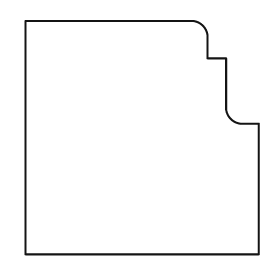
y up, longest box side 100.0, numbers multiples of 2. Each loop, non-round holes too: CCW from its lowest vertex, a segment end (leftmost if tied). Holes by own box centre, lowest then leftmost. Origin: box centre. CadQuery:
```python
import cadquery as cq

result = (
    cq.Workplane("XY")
    .moveTo(-50.0, -50.0)
    .lineTo(50.0, -50.0)
    .lineTo(50.0, 6.0)
    .lineTo(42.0, 6.0)
    .threePointArc((38.0, 8.0), (36.0, 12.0))
    .lineTo(36.0, 34.0)
    .lineTo(28.0, 34.0)
    .lineTo(28.0, 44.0)
    .threePointArc((26.0, 48.0), (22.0, 50.0))
    .lineTo(-50.0, 50.0)
    .close()
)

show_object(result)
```